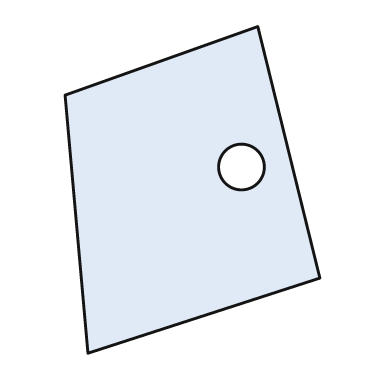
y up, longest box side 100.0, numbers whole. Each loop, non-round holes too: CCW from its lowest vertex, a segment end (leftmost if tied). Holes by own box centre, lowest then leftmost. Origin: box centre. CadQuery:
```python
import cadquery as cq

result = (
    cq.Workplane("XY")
    .moveTo(-32.0, -50.0)
    .lineTo(39.0, -27.0)
    .lineTo(20.0, 50.0)
    .lineTo(-39.0, 29.0)
    .close()
    .moveTo(15.0, 7.0)
    .circle(7.0)
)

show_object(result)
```